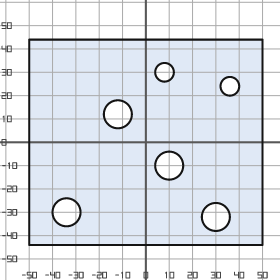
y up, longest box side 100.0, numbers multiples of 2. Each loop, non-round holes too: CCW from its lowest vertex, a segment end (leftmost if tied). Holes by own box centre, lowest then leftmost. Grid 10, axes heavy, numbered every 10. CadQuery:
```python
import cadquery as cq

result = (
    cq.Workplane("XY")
    .moveTo(-50.0, -44.0)
    .lineTo(50.0, -44.0)
    .lineTo(50.0, 44.0)
    .lineTo(-50.0, 44.0)
    .close()
    .moveTo(30.0, -32.0)
    .circle(6.0)
    .moveTo(-34.0, -30.0)
    .circle(6.0)
    .moveTo(10.0, -10.0)
    .circle(6.0)
    .moveTo(-12.0, 12.0)
    .circle(6.0)
    .moveTo(36.0, 24.0)
    .circle(4.0)
    .moveTo(8.0, 30.0)
    .circle(4.0)
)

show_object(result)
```